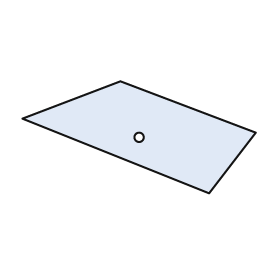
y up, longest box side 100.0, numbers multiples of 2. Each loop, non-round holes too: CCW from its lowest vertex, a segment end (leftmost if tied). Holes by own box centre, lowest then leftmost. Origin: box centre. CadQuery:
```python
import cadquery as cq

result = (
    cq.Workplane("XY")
    .moveTo(30.0, -24.0)
    .lineTo(50.0, 2.0)
    .lineTo(-8.0, 24.0)
    .lineTo(-50.0, 8.0)
    .close()
    .moveTo(0.0, 0.0)
    .circle(2.0)
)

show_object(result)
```